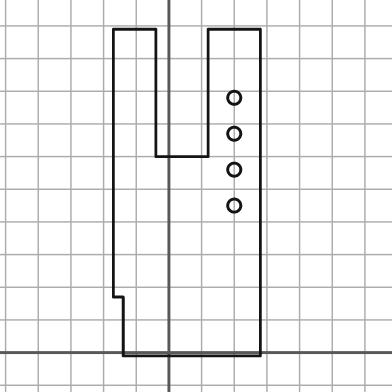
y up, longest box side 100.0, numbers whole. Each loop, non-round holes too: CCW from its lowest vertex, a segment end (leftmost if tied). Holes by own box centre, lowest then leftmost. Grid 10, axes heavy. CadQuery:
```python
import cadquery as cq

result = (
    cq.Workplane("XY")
    .moveTo(-14.0, -1.0)
    .lineTo(28.0, -1.0)
    .lineTo(28.0, 99.0)
    .lineTo(12.0, 99.0)
    .lineTo(12.0, 60.0)
    .lineTo(-4.0, 60.0)
    .lineTo(-4.0, 99.0)
    .lineTo(-17.0, 99.0)
    .lineTo(-17.0, 17.0)
    .lineTo(-14.0, 17.0)
    .close()
    .moveTo(20.0, 45.0)
    .circle(2.0)
    .moveTo(20.0, 56.0)
    .circle(2.0)
    .moveTo(20.0, 67.0)
    .circle(2.0)
    .moveTo(20.0, 78.0)
    .circle(2.0)
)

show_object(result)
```